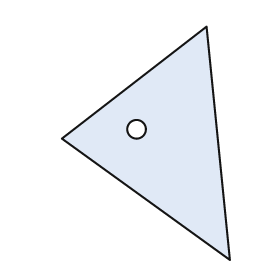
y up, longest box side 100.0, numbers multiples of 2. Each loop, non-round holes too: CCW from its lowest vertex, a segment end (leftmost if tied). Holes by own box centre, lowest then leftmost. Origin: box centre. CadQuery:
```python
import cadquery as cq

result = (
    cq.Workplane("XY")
    .moveTo(36.0, -50.0)
    .lineTo(26.0, 50.0)
    .lineTo(-36.0, 2.0)
    .close()
    .moveTo(-4.0, 6.0)
    .circle(4.0)
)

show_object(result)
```